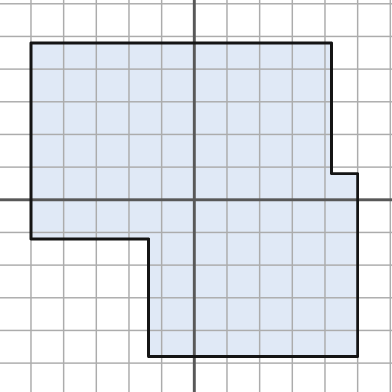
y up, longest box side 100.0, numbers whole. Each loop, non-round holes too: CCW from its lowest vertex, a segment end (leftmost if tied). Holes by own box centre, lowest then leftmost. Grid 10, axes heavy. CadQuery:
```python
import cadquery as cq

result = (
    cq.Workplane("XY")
    .moveTo(-14.0, -48.0)
    .lineTo(50.0, -48.0)
    .lineTo(50.0, 8.0)
    .lineTo(42.0, 8.0)
    .lineTo(42.0, 48.0)
    .lineTo(-50.0, 48.0)
    .lineTo(-50.0, -12.0)
    .lineTo(-14.0, -12.0)
    .close()
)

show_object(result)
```